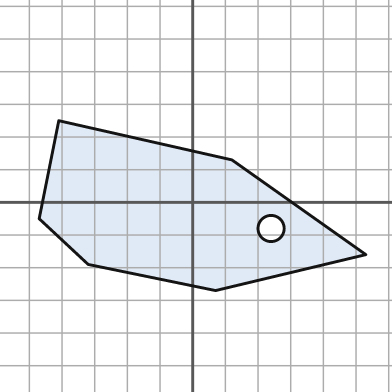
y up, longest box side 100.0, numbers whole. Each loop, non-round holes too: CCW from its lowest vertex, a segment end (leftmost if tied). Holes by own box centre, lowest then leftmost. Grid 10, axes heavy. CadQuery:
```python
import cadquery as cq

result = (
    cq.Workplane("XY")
    .moveTo(7.0, -27.0)
    .lineTo(53.0, -16.0)
    .lineTo(12.0, 13.0)
    .lineTo(-41.0, 25.0)
    .lineTo(-47.0, -5.0)
    .lineTo(-32.0, -19.0)
    .close()
    .moveTo(24.0, -8.0)
    .circle(4.0)
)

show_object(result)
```